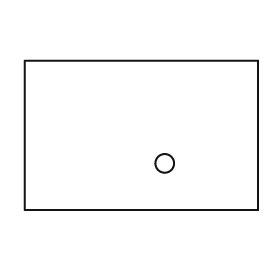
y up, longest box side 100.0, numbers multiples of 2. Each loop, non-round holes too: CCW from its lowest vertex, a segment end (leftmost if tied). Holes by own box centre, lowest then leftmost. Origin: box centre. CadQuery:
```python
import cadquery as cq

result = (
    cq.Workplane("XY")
    .moveTo(-50.0, -32.0)
    .lineTo(50.0, -32.0)
    .lineTo(50.0, 32.0)
    .lineTo(-50.0, 32.0)
    .close()
    .moveTo(10.0, -12.0)
    .circle(4.0)
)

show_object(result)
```